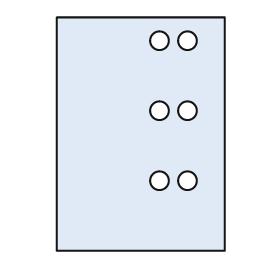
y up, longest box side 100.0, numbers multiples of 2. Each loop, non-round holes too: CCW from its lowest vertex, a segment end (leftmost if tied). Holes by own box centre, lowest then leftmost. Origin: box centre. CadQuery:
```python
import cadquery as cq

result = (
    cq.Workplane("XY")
    .moveTo(-36.0, -50.0)
    .lineTo(36.0, -50.0)
    .lineTo(36.0, 50.0)
    .lineTo(-36.0, 50.0)
    .close()
    .moveTo(8.0, -20.0)
    .circle(4.0)
    .moveTo(20.0, -20.0)
    .circle(4.0)
    .moveTo(8.0, 10.0)
    .circle(4.0)
    .moveTo(20.0, 10.0)
    .circle(4.0)
    .moveTo(8.0, 40.0)
    .circle(4.0)
    .moveTo(20.0, 40.0)
    .circle(4.0)
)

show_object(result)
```